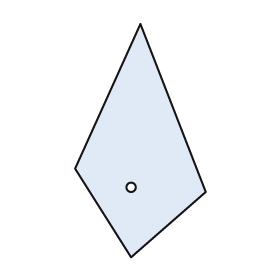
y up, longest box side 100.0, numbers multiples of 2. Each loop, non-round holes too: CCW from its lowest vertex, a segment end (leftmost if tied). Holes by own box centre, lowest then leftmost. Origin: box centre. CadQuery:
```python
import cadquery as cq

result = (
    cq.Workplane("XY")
    .moveTo(-4.0, -50.0)
    .lineTo(28.0, -22.0)
    .lineTo(0.0, 50.0)
    .lineTo(-28.0, -12.0)
    .close()
    .moveTo(-4.0, -20.0)
    .circle(2.0)
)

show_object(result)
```